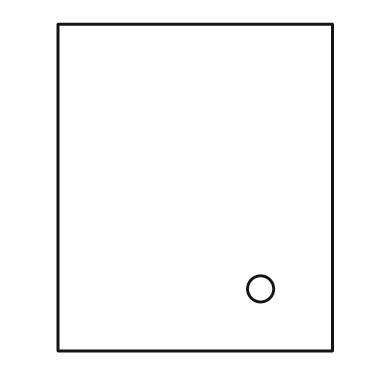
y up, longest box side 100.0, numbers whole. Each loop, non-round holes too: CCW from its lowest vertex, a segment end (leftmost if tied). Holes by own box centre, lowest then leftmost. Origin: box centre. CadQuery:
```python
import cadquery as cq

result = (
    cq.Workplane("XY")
    .moveTo(-42.0, -50.0)
    .lineTo(42.0, -50.0)
    .lineTo(42.0, 50.0)
    .lineTo(-42.0, 50.0)
    .close()
    .moveTo(20.0, -31.0)
    .circle(4.0)
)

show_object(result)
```